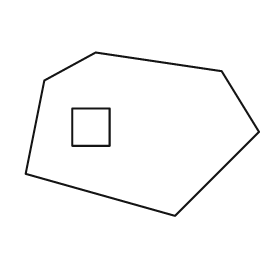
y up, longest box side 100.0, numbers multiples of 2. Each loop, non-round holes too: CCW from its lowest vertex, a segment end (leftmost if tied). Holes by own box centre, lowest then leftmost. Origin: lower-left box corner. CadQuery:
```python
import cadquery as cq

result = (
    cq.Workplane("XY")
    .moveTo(64.0, 0.0)
    .lineTo(100.0, 36.0)
    .lineTo(84.0, 62.0)
    .lineTo(30.0, 70.0)
    .lineTo(8.0, 58.0)
    .lineTo(0.0, 18.0)
    .close()
    .moveTo(20.0, 30.0)
    .lineTo(36.0, 30.0)
    .lineTo(36.0, 46.0)
    .lineTo(20.0, 46.0)
    .close()
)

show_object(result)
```